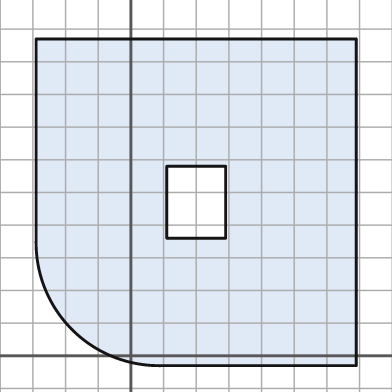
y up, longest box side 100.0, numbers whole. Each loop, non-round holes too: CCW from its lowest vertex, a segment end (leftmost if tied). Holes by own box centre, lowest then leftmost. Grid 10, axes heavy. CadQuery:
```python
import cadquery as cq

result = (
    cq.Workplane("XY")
    .moveTo(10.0, -3.0)
    .lineTo(69.0, -3.0)
    .lineTo(69.0, 97.0)
    .lineTo(-29.0, 97.0)
    .lineTo(-29.0, 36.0)
    .threePointArc((-18.0, 8.0), (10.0, -3.0))
    .close()
    .moveTo(11.0, 36.0)
    .lineTo(29.0, 36.0)
    .lineTo(29.0, 58.0)
    .lineTo(11.0, 58.0)
    .close()
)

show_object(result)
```